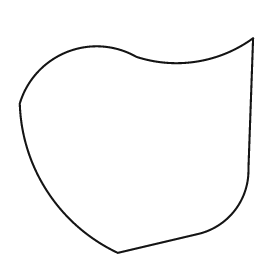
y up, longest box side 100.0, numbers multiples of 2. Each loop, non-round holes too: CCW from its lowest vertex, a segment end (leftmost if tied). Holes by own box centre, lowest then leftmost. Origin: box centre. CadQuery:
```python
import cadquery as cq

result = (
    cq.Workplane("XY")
    .moveTo(-8.0, -46.0)
    .lineTo(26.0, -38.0)
    .threePointArc((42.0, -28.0), (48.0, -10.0))
    .lineTo(50.0, 46.0)
    .threePointArc((26.0, 36.0), (0.0, 38.0))
    .threePointArc((-30.0, 40.0), (-50.0, 18.0))
    .threePointArc((-38.0, -20.0), (-8.0, -46.0))
    .close()
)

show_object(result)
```